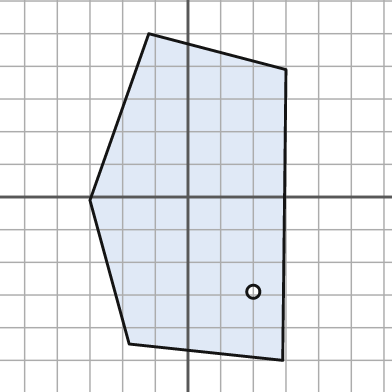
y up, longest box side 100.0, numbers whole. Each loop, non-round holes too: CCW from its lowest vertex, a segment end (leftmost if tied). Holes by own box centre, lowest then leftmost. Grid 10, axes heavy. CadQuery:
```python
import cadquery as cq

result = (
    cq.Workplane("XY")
    .moveTo(29.0, -50.0)
    .lineTo(30.0, 39.0)
    .lineTo(-12.0, 50.0)
    .lineTo(-30.0, -1.0)
    .lineTo(-18.0, -45.0)
    .close()
    .moveTo(20.0, -29.0)
    .circle(2.0)
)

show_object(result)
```